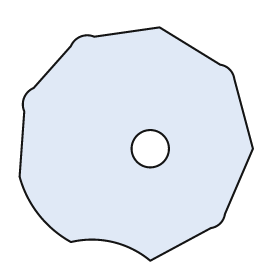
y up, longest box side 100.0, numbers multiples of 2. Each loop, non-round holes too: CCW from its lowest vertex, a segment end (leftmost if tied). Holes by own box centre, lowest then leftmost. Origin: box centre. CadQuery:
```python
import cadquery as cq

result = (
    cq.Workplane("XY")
    .moveTo(6.0, -50.0)
    .lineTo(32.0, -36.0)
    .threePointArc((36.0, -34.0), (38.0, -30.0))
    .lineTo(50.0, -2.0)
    .lineTo(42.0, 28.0)
    .threePointArc((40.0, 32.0), (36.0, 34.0))
    .lineTo(10.0, 50.0)
    .lineTo(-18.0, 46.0)
    .threePointArc((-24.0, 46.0), (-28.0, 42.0))
    .lineTo(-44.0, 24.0)
    .threePointArc((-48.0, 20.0), (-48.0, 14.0))
    .lineTo(-50.0, -14.0)
    .threePointArc((-42.0, -30.0), (-28.0, -42.0))
    .threePointArc((-10.0, -42.0), (6.0, -50.0))
    .close()
    .moveTo(6.0, -2.0)
    .circle(8.0)
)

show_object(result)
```